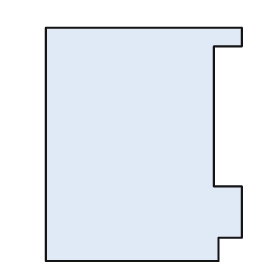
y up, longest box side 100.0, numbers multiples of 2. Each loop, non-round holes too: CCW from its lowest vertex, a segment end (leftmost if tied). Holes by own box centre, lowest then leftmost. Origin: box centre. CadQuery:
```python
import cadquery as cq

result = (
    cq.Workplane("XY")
    .moveTo(-42.0, -50.0)
    .lineTo(32.0, -50.0)
    .lineTo(32.0, -40.0)
    .lineTo(42.0, -40.0)
    .lineTo(42.0, -18.0)
    .lineTo(30.0, -18.0)
    .lineTo(30.0, 42.0)
    .lineTo(42.0, 42.0)
    .lineTo(42.0, 50.0)
    .lineTo(-42.0, 50.0)
    .close()
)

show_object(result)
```